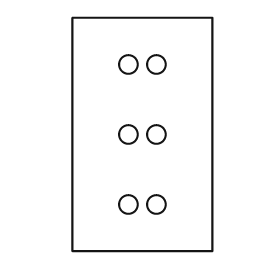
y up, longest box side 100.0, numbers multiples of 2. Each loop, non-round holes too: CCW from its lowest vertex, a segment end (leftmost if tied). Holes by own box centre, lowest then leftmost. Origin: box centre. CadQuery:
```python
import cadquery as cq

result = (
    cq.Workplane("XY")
    .moveTo(-30.0, -50.0)
    .lineTo(30.0, -50.0)
    .lineTo(30.0, 50.0)
    .lineTo(-30.0, 50.0)
    .close()
    .moveTo(-6.0, -30.0)
    .circle(4.0)
    .moveTo(6.0, -30.0)
    .circle(4.0)
    .moveTo(-6.0, 0.0)
    .circle(4.0)
    .moveTo(6.0, 0.0)
    .circle(4.0)
    .moveTo(-6.0, 30.0)
    .circle(4.0)
    .moveTo(6.0, 30.0)
    .circle(4.0)
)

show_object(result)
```